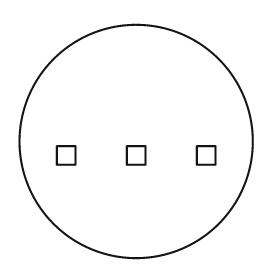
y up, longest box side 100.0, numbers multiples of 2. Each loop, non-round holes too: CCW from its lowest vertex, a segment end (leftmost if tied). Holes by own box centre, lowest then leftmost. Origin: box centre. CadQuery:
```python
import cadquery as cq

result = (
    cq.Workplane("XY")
    .moveTo(0.0, 0.0)
    .circle(50.0)
    .moveTo(-34.0, -10.0)
    .lineTo(-26.0, -10.0)
    .lineTo(-26.0, -2.0)
    .lineTo(-34.0, -2.0)
    .close()
    .moveTo(-4.0, -10.0)
    .lineTo(4.0, -10.0)
    .lineTo(4.0, -2.0)
    .lineTo(-4.0, -2.0)
    .close()
    .moveTo(26.0, -10.0)
    .lineTo(34.0, -10.0)
    .lineTo(34.0, -2.0)
    .lineTo(26.0, -2.0)
    .close()
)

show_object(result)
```